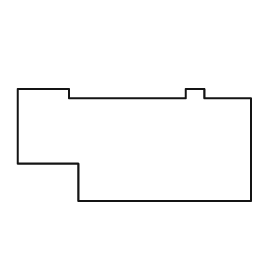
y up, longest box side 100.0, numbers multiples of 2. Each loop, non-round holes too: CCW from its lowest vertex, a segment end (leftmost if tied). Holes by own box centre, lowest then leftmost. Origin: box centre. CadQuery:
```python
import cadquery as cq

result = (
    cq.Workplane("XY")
    .moveTo(-24.0, -24.0)
    .lineTo(50.0, -24.0)
    .lineTo(50.0, 20.0)
    .lineTo(30.0, 20.0)
    .lineTo(30.0, 24.0)
    .lineTo(22.0, 24.0)
    .lineTo(22.0, 20.0)
    .lineTo(-28.0, 20.0)
    .lineTo(-28.0, 24.0)
    .lineTo(-50.0, 24.0)
    .lineTo(-50.0, -8.0)
    .lineTo(-24.0, -8.0)
    .close()
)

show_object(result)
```